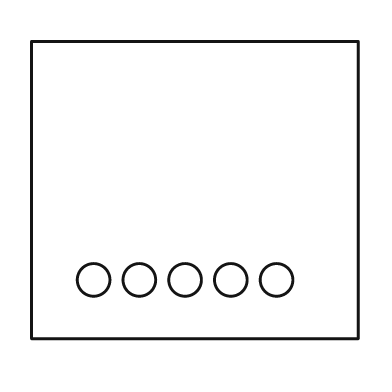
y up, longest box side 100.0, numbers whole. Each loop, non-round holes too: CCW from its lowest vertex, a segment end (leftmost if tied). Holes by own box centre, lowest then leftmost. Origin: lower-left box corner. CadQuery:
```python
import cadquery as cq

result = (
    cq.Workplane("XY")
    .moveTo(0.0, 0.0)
    .lineTo(100.0, 0.0)
    .lineTo(100.0, 91.0)
    .lineTo(0.0, 91.0)
    .close()
    .moveTo(19.0, 18.0)
    .circle(5.0)
    .moveTo(33.0, 18.0)
    .circle(5.0)
    .moveTo(47.0, 18.0)
    .circle(5.0)
    .moveTo(61.0, 18.0)
    .circle(5.0)
    .moveTo(75.0, 18.0)
    .circle(5.0)
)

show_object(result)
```